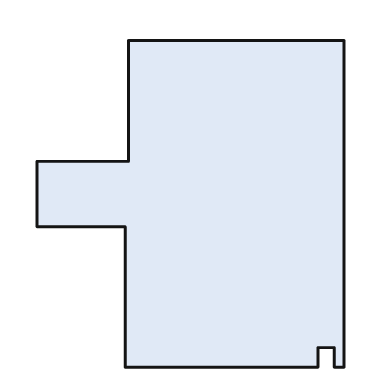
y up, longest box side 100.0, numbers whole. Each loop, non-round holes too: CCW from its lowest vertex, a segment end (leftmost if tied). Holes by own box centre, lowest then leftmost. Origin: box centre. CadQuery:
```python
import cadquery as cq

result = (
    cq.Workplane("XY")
    .moveTo(-20.0, -50.0)
    .lineTo(39.0, -50.0)
    .lineTo(39.0, -44.0)
    .lineTo(44.0, -44.0)
    .lineTo(44.0, -50.0)
    .lineTo(47.0, -50.0)
    .lineTo(47.0, 50.0)
    .lineTo(-19.0, 50.0)
    .lineTo(-19.0, 13.0)
    .lineTo(-47.0, 13.0)
    .lineTo(-47.0, -7.0)
    .lineTo(-20.0, -7.0)
    .close()
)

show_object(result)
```